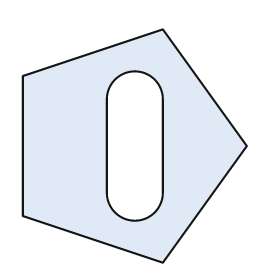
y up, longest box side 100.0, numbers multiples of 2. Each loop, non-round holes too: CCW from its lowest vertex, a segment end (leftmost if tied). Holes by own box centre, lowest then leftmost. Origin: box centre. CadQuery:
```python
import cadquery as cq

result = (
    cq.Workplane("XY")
    .moveTo(12.0, -50.0)
    .lineTo(48.0, 0.0)
    .lineTo(12.0, 50.0)
    .lineTo(-48.0, 30.0)
    .lineTo(-48.0, -30.0)
    .close()
    .moveTo(-12.0, -20.0)
    .threePointArc((0.0, -32.0), (12.0, -20.0))
    .lineTo(12.0, 20.0)
    .threePointArc((0.0, 32.0), (-12.0, 20.0))
    .close()
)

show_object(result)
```